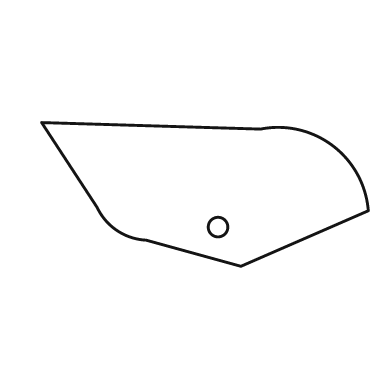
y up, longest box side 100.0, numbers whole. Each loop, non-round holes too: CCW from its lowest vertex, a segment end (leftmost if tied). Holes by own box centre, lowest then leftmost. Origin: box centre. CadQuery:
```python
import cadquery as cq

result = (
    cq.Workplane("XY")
    .moveTo(11.0, -22.0)
    .lineTo(50.0, -5.0)
    .threePointArc((39.0, 15.0), (17.0, 20.0))
    .lineTo(-50.0, 22.0)
    .lineTo(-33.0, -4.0)
    .threePointArc((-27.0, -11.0), (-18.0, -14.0))
    .close()
    .moveTo(4.0, -10.0)
    .circle(3.0)
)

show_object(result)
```